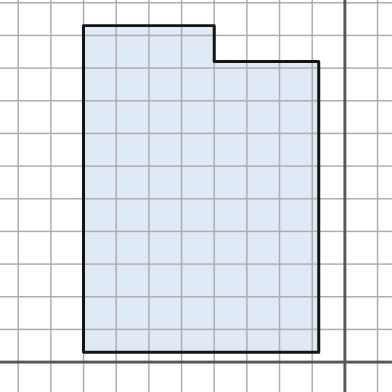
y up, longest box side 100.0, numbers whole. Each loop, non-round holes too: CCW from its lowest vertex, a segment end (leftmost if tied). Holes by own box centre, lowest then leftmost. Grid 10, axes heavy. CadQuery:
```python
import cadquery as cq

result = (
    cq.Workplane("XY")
    .moveTo(-80.0, 3.0)
    .lineTo(-8.0, 3.0)
    .lineTo(-8.0, 92.0)
    .lineTo(-40.0, 92.0)
    .lineTo(-40.0, 103.0)
    .lineTo(-80.0, 103.0)
    .close()
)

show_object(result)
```